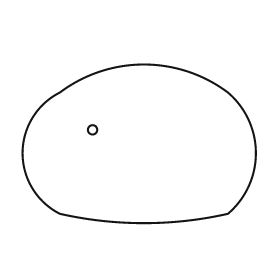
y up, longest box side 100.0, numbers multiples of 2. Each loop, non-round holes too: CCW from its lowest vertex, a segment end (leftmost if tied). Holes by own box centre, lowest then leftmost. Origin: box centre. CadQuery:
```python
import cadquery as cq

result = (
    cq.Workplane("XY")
    .moveTo(-34.0, -30.0)
    .threePointArc((2.0, -34.0), (38.0, -30.0))
    .threePointArc((50.0, -4.0), (38.0, 22.0))
    .threePointArc((2.0, 34.0), (-34.0, 22.0))
    .threePointArc((-50.0, -4.0), (-34.0, -30.0))
    .close()
    .moveTo(-20.0, 6.0)
    .circle(2.0)
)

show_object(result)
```